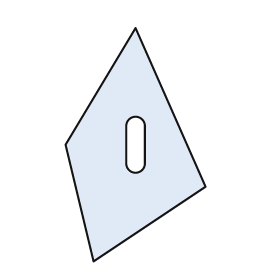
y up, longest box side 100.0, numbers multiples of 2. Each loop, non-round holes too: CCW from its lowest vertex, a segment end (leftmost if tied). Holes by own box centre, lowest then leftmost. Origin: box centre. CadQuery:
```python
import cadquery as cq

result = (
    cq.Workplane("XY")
    .moveTo(-18.0, -50.0)
    .lineTo(30.0, -18.0)
    .lineTo(0.0, 50.0)
    .lineTo(-30.0, 0.0)
    .close()
    .moveTo(-4.0, -8.0)
    .threePointArc((0.0, -12.0), (4.0, -8.0))
    .lineTo(4.0, 8.0)
    .threePointArc((0.0, 12.0), (-4.0, 8.0))
    .close()
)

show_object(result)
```